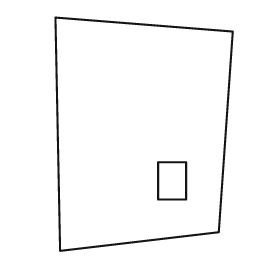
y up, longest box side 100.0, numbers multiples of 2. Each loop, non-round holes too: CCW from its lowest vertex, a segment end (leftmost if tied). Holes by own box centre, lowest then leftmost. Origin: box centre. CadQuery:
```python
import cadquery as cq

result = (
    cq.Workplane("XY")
    .moveTo(-36.0, -50.0)
    .lineTo(32.0, -42.0)
    .lineTo(38.0, 44.0)
    .lineTo(-38.0, 50.0)
    .close()
    .moveTo(6.0, -28.0)
    .lineTo(18.0, -28.0)
    .lineTo(18.0, -12.0)
    .lineTo(6.0, -12.0)
    .close()
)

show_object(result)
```